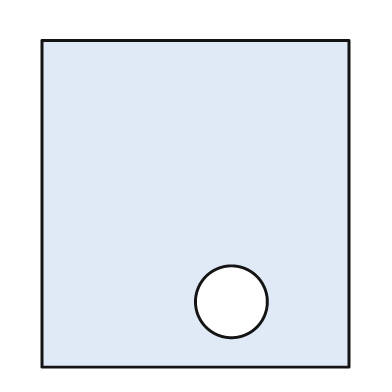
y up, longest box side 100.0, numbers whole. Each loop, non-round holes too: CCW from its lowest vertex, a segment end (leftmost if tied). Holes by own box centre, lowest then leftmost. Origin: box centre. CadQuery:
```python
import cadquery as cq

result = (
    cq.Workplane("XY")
    .moveTo(-47.0, -50.0)
    .lineTo(47.0, -50.0)
    .lineTo(47.0, 50.0)
    .lineTo(-47.0, 50.0)
    .close()
    .moveTo(11.0, -30.0)
    .circle(11.0)
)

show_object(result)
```